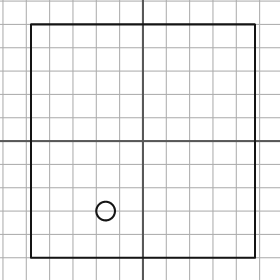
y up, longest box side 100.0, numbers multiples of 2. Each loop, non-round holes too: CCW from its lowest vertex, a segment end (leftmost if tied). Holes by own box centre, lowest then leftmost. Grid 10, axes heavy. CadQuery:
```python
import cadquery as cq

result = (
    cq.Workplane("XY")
    .moveTo(-48.0, -50.0)
    .lineTo(48.0, -50.0)
    .lineTo(48.0, 50.0)
    .lineTo(-48.0, 50.0)
    .close()
    .moveTo(-16.0, -30.0)
    .circle(4.0)
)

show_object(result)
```